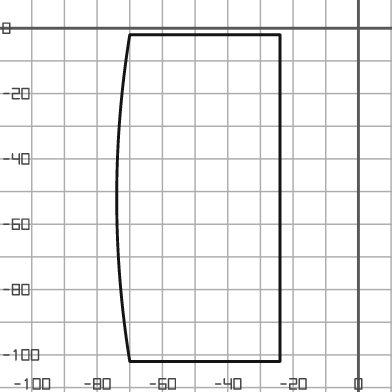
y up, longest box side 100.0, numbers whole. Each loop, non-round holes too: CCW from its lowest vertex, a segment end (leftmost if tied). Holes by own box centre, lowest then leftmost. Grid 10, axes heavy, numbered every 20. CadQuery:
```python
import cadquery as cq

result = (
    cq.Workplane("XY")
    .moveTo(-70.0, -102.0)
    .lineTo(-24.0, -102.0)
    .lineTo(-24.0, -2.0)
    .lineTo(-70.0, -2.0)
    .threePointArc((-74.0, -52.0), (-70.0, -102.0))
    .close()
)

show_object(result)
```